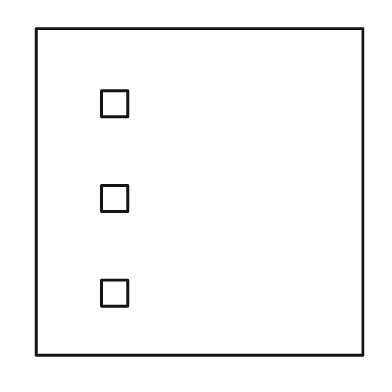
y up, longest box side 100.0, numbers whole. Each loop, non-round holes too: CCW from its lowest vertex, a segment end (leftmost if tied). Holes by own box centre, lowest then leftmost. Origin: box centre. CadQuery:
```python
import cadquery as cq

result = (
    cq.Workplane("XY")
    .moveTo(-50.0, -50.0)
    .lineTo(50.0, -50.0)
    .lineTo(50.0, 50.0)
    .lineTo(-50.0, 50.0)
    .close()
    .moveTo(-30.0, -35.0)
    .lineTo(-22.0, -35.0)
    .lineTo(-22.0, -27.0)
    .lineTo(-30.0, -27.0)
    .close()
    .moveTo(-30.0, -6.0)
    .lineTo(-22.0, -6.0)
    .lineTo(-22.0, 2.0)
    .lineTo(-30.0, 2.0)
    .close()
    .moveTo(-30.0, 23.0)
    .lineTo(-22.0, 23.0)
    .lineTo(-22.0, 31.0)
    .lineTo(-30.0, 31.0)
    .close()
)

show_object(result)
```